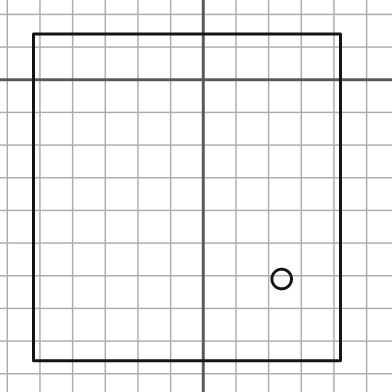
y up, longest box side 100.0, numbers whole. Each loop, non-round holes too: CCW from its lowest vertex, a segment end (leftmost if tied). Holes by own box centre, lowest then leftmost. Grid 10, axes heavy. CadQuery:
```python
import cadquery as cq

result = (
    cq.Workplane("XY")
    .moveTo(-52.0, -86.0)
    .lineTo(42.0, -86.0)
    .lineTo(42.0, 14.0)
    .lineTo(-52.0, 14.0)
    .close()
    .moveTo(24.0, -61.0)
    .circle(3.0)
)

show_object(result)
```